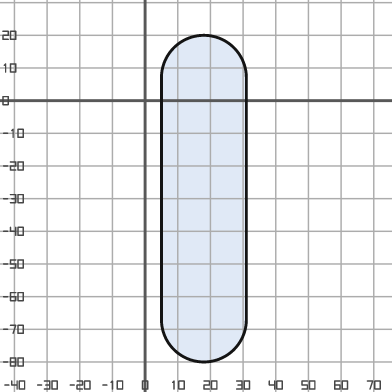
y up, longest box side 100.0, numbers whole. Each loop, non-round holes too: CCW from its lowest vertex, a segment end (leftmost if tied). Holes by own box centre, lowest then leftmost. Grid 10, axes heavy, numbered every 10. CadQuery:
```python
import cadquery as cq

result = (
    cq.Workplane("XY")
    .moveTo(5.0, -67.0)
    .threePointArc((18.0, -80.0), (31.0, -67.0))
    .lineTo(31.0, 7.0)
    .threePointArc((18.0, 20.0), (5.0, 7.0))
    .close()
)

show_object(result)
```